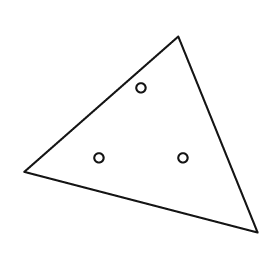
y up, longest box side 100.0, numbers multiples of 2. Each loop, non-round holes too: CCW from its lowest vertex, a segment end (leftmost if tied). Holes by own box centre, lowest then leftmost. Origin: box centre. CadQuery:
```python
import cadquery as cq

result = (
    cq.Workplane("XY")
    .moveTo(50.0, -42.0)
    .lineTo(16.0, 42.0)
    .lineTo(-50.0, -16.0)
    .close()
    .moveTo(-18.0, -10.0)
    .circle(2.0)
    .moveTo(18.0, -10.0)
    .circle(2.0)
    .moveTo(0.0, 20.0)
    .circle(2.0)
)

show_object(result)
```